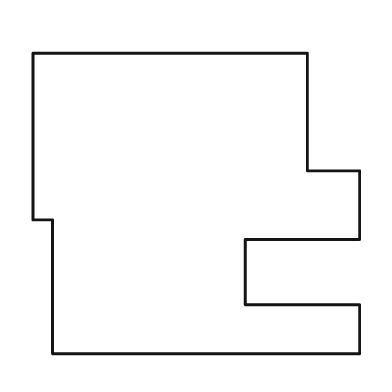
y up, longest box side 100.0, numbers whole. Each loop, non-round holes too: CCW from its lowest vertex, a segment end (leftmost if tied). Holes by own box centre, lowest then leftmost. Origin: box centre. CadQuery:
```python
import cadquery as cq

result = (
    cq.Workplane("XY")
    .moveTo(-44.0, -46.0)
    .lineTo(50.0, -46.0)
    .lineTo(50.0, -31.0)
    .lineTo(15.0, -31.0)
    .lineTo(15.0, -11.0)
    .lineTo(50.0, -11.0)
    .lineTo(50.0, 10.0)
    .lineTo(34.0, 10.0)
    .lineTo(34.0, 46.0)
    .lineTo(-50.0, 46.0)
    .lineTo(-50.0, -5.0)
    .lineTo(-44.0, -5.0)
    .close()
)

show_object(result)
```